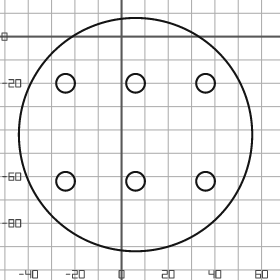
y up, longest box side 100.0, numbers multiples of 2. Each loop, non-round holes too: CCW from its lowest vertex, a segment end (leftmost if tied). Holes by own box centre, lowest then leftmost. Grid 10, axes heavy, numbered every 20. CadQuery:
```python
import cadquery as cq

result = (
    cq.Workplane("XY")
    .moveTo(6.0, -42.0)
    .circle(50.0)
    .moveTo(-24.0, -62.0)
    .circle(4.0)
    .moveTo(6.0, -62.0)
    .circle(4.0)
    .moveTo(36.0, -62.0)
    .circle(4.0)
    .moveTo(-24.0, -20.0)
    .circle(4.0)
    .moveTo(6.0, -20.0)
    .circle(4.0)
    .moveTo(36.0, -20.0)
    .circle(4.0)
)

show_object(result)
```